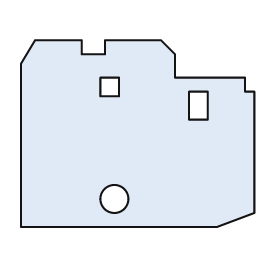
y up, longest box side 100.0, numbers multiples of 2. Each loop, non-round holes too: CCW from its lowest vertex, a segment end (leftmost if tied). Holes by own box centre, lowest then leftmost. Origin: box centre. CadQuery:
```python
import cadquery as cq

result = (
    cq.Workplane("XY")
    .moveTo(-50.0, -40.0)
    .lineTo(34.0, -40.0)
    .lineTo(50.0, -34.0)
    .lineTo(50.0, 18.0)
    .lineTo(46.0, 18.0)
    .lineTo(46.0, 24.0)
    .lineTo(16.0, 24.0)
    .lineTo(16.0, 34.0)
    .lineTo(10.0, 40.0)
    .lineTo(-14.0, 40.0)
    .lineTo(-14.0, 34.0)
    .lineTo(-24.0, 34.0)
    .lineTo(-24.0, 40.0)
    .lineTo(-44.0, 40.0)
    .lineTo(-50.0, 30.0)
    .close()
    .moveTo(-10.0, -28.0)
    .circle(6.0)
    .moveTo(22.0, 6.0)
    .lineTo(30.0, 6.0)
    .lineTo(30.0, 18.0)
    .lineTo(22.0, 18.0)
    .close()
    .moveTo(-16.0, 16.0)
    .lineTo(-8.0, 16.0)
    .lineTo(-8.0, 24.0)
    .lineTo(-16.0, 24.0)
    .close()
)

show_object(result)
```